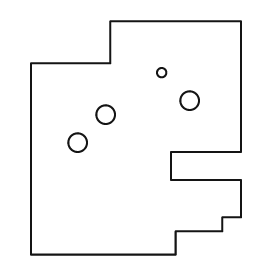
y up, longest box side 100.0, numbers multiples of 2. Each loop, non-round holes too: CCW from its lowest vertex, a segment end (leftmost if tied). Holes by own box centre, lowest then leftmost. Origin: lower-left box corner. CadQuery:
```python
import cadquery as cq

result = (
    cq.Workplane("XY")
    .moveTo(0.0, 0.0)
    .lineTo(62.0, 0.0)
    .lineTo(62.0, 10.0)
    .lineTo(82.0, 10.0)
    .lineTo(82.0, 16.0)
    .lineTo(90.0, 16.0)
    .lineTo(90.0, 32.0)
    .lineTo(60.0, 32.0)
    .lineTo(60.0, 44.0)
    .lineTo(90.0, 44.0)
    .lineTo(90.0, 100.0)
    .lineTo(34.0, 100.0)
    .lineTo(34.0, 82.0)
    .lineTo(0.0, 82.0)
    .close()
    .moveTo(20.0, 48.0)
    .circle(4.0)
    .moveTo(32.0, 60.0)
    .circle(4.0)
    .moveTo(68.0, 66.0)
    .circle(4.0)
    .moveTo(56.0, 78.0)
    .circle(2.0)
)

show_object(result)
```